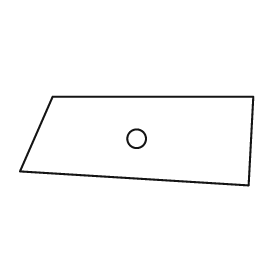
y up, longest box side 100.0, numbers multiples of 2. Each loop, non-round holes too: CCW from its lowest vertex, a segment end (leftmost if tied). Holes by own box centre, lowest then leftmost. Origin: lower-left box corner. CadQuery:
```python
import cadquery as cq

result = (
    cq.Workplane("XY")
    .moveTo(98.0, 0.0)
    .lineTo(100.0, 38.0)
    .lineTo(14.0, 38.0)
    .lineTo(0.0, 6.0)
    .close()
    .moveTo(50.0, 20.0)
    .circle(4.0)
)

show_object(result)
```